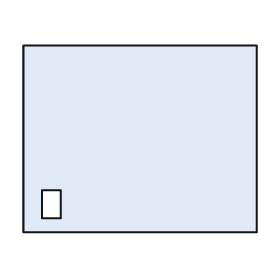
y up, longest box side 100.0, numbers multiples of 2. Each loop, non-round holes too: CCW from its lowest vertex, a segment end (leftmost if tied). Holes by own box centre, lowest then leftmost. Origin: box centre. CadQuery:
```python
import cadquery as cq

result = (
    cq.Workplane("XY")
    .moveTo(-50.0, -40.0)
    .lineTo(50.0, -40.0)
    .lineTo(50.0, 40.0)
    .lineTo(-50.0, 40.0)
    .close()
    .moveTo(-42.0, -34.0)
    .lineTo(-34.0, -34.0)
    .lineTo(-34.0, -22.0)
    .lineTo(-42.0, -22.0)
    .close()
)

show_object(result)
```